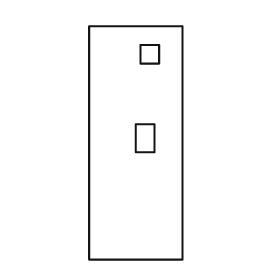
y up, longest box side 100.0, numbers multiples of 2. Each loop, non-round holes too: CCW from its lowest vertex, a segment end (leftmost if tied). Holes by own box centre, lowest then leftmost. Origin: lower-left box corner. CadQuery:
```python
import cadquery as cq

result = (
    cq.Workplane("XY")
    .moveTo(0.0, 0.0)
    .lineTo(40.0, 0.0)
    .lineTo(40.0, 100.0)
    .lineTo(0.0, 100.0)
    .close()
    .moveTo(20.0, 46.0)
    .lineTo(28.0, 46.0)
    .lineTo(28.0, 58.0)
    .lineTo(20.0, 58.0)
    .close()
    .moveTo(22.0, 84.0)
    .lineTo(30.0, 84.0)
    .lineTo(30.0, 92.0)
    .lineTo(22.0, 92.0)
    .close()
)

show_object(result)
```